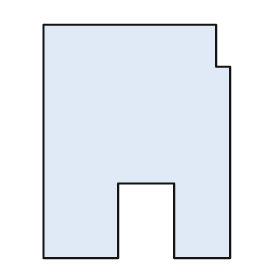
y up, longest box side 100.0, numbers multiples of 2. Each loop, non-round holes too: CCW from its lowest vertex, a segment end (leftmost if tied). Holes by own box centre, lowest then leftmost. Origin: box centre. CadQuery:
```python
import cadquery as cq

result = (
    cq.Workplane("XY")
    .moveTo(-40.0, -50.0)
    .lineTo(-8.0, -50.0)
    .lineTo(-8.0, -18.0)
    .lineTo(16.0, -18.0)
    .lineTo(16.0, -50.0)
    .lineTo(40.0, -50.0)
    .lineTo(40.0, 32.0)
    .lineTo(34.0, 32.0)
    .lineTo(34.0, 50.0)
    .lineTo(-40.0, 50.0)
    .close()
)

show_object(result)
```